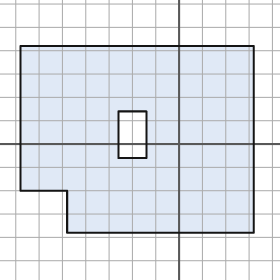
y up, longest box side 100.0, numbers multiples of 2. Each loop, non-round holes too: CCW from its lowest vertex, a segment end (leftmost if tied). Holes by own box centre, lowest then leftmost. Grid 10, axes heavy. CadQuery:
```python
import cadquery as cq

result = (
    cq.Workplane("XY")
    .moveTo(-48.0, -38.0)
    .lineTo(32.0, -38.0)
    .lineTo(32.0, 42.0)
    .lineTo(-68.0, 42.0)
    .lineTo(-68.0, -20.0)
    .lineTo(-48.0, -20.0)
    .close()
    .moveTo(-26.0, -6.0)
    .lineTo(-14.0, -6.0)
    .lineTo(-14.0, 14.0)
    .lineTo(-26.0, 14.0)
    .close()
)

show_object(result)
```